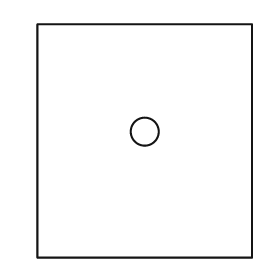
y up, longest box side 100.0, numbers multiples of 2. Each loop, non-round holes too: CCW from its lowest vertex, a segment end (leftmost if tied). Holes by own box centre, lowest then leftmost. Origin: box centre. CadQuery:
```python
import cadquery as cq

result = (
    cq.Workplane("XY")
    .moveTo(-46.0, -50.0)
    .lineTo(46.0, -50.0)
    .lineTo(46.0, 50.0)
    .lineTo(-46.0, 50.0)
    .close()
    .moveTo(0.0, 4.0)
    .circle(6.0)
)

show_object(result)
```